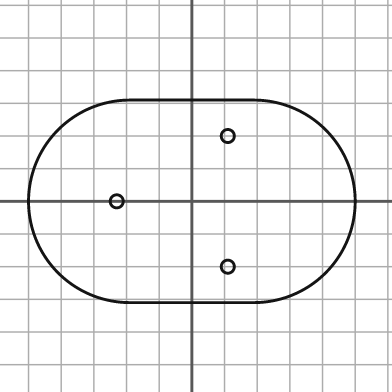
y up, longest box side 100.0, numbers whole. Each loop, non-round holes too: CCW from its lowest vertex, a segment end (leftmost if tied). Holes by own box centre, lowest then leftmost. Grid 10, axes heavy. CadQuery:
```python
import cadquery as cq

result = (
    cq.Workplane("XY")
    .moveTo(-19.0, -31.0)
    .lineTo(19.0, -31.0)
    .threePointArc((50.0, 0.0), (19.0, 31.0))
    .lineTo(-19.0, 31.0)
    .threePointArc((-50.0, 0.0), (-19.0, -31.0))
    .close()
    .moveTo(11.0, -20.0)
    .circle(2.0)
    .moveTo(-23.0, 0.0)
    .circle(2.0)
    .moveTo(11.0, 20.0)
    .circle(2.0)
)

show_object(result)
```